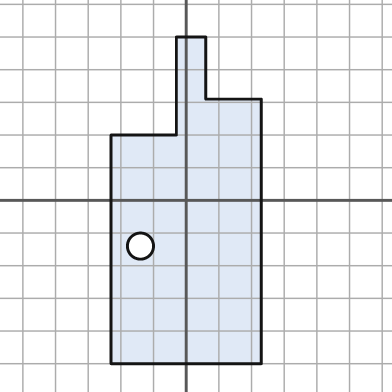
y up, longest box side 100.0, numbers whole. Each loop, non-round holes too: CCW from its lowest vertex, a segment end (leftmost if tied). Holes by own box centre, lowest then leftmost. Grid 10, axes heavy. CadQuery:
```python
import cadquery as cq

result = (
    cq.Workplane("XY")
    .moveTo(-23.0, -50.0)
    .lineTo(23.0, -50.0)
    .lineTo(23.0, 31.0)
    .lineTo(6.0, 31.0)
    .lineTo(6.0, 50.0)
    .lineTo(-3.0, 50.0)
    .lineTo(-3.0, 20.0)
    .lineTo(-23.0, 20.0)
    .close()
    .moveTo(-14.0, -14.0)
    .circle(4.0)
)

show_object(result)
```